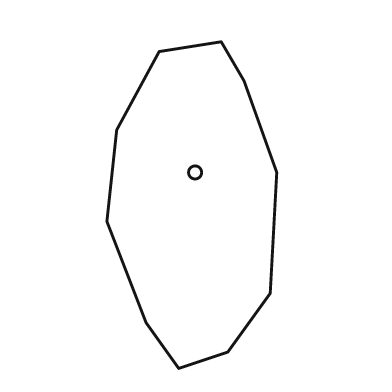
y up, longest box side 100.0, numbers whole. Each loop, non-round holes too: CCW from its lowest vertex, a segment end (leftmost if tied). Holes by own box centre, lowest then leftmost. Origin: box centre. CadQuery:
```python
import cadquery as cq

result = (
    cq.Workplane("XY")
    .moveTo(-4.0, -50.0)
    .lineTo(11.0, -45.0)
    .lineTo(24.0, -27.0)
    .lineTo(26.0, 10.0)
    .lineTo(16.0, 38.0)
    .lineTo(9.0, 50.0)
    .lineTo(-10.0, 47.0)
    .lineTo(-23.0, 23.0)
    .lineTo(-26.0, -5.0)
    .lineTo(-14.0, -36.0)
    .close()
    .moveTo(1.0, 10.0)
    .circle(2.0)
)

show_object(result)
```